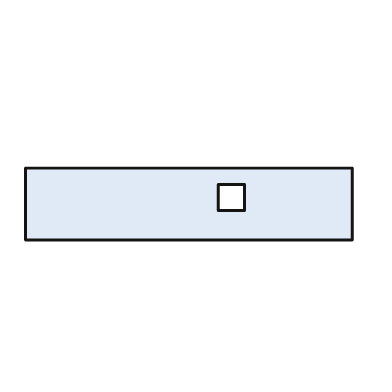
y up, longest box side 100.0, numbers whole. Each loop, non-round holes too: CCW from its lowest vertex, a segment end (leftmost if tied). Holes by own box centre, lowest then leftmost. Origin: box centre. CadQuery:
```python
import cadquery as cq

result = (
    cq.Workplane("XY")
    .moveTo(-50.0, -11.0)
    .lineTo(50.0, -11.0)
    .lineTo(50.0, 11.0)
    .lineTo(-50.0, 11.0)
    .close()
    .moveTo(9.0, -2.0)
    .lineTo(17.0, -2.0)
    .lineTo(17.0, 6.0)
    .lineTo(9.0, 6.0)
    .close()
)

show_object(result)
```